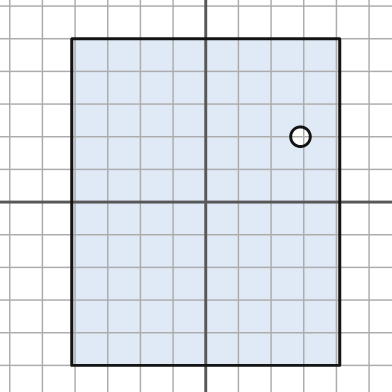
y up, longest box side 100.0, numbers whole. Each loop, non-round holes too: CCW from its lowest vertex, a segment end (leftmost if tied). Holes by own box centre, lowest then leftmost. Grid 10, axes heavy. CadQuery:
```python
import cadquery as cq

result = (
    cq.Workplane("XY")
    .moveTo(-41.0, -50.0)
    .lineTo(41.0, -50.0)
    .lineTo(41.0, 50.0)
    .lineTo(-41.0, 50.0)
    .close()
    .moveTo(29.0, 20.0)
    .circle(3.0)
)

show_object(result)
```